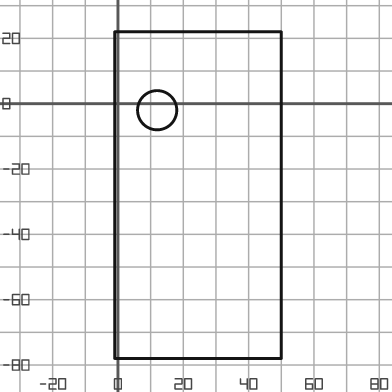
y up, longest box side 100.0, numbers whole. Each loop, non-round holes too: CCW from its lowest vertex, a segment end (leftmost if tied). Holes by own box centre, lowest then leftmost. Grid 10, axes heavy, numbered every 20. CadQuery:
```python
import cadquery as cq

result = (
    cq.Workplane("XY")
    .moveTo(-1.0, -78.0)
    .lineTo(50.0, -78.0)
    .lineTo(50.0, 22.0)
    .lineTo(-1.0, 22.0)
    .close()
    .moveTo(12.0, -2.0)
    .circle(6.0)
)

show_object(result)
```